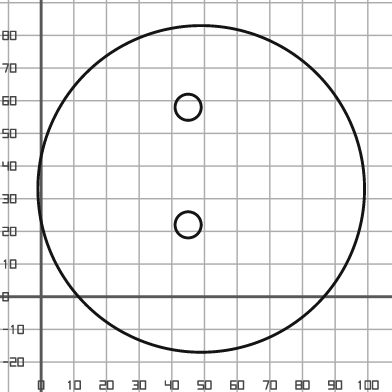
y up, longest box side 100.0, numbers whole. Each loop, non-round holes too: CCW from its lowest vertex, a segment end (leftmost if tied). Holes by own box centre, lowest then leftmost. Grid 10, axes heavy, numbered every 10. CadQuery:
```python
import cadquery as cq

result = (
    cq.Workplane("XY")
    .moveTo(49.0, 33.0)
    .circle(50.0)
    .moveTo(45.0, 22.0)
    .circle(4.0)
    .moveTo(45.0, 58.0)
    .circle(4.0)
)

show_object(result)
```